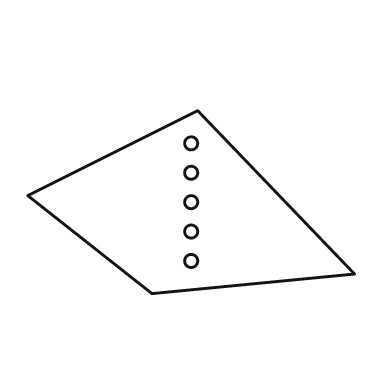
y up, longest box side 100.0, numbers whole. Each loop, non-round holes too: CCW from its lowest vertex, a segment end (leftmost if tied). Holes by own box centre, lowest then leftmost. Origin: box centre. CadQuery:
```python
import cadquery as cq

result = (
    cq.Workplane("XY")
    .moveTo(-12.0, -28.0)
    .lineTo(50.0, -22.0)
    .lineTo(2.0, 28.0)
    .lineTo(-50.0, 2.0)
    .close()
    .moveTo(0.0, -18.0)
    .circle(2.0)
    .moveTo(0.0, -9.0)
    .circle(2.0)
    .moveTo(0.0, 0.0)
    .circle(2.0)
    .moveTo(0.0, 9.0)
    .circle(2.0)
    .moveTo(0.0, 18.0)
    .circle(2.0)
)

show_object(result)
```